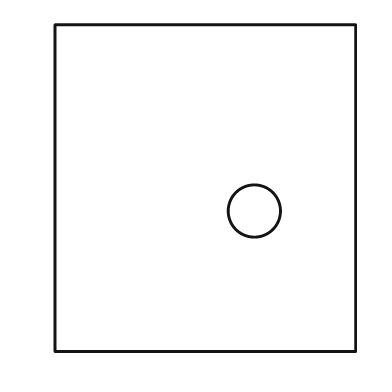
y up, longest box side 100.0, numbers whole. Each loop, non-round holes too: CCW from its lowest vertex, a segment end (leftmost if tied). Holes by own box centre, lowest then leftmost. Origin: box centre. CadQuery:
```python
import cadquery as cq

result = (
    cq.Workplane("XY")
    .moveTo(-46.0, -50.0)
    .lineTo(46.0, -50.0)
    .lineTo(46.0, 50.0)
    .lineTo(-46.0, 50.0)
    .close()
    .moveTo(15.0, -7.0)
    .circle(8.0)
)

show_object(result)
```